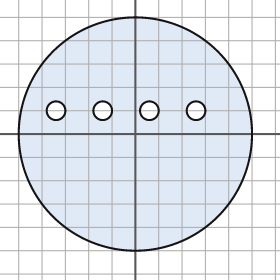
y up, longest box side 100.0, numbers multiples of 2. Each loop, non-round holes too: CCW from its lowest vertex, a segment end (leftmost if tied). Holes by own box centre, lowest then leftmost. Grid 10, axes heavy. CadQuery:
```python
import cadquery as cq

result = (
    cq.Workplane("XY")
    .moveTo(0.0, 0.0)
    .circle(50.0)
    .moveTo(-34.0, 10.0)
    .circle(4.0)
    .moveTo(-14.0, 10.0)
    .circle(4.0)
    .moveTo(6.0, 10.0)
    .circle(4.0)
    .moveTo(26.0, 10.0)
    .circle(4.0)
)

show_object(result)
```